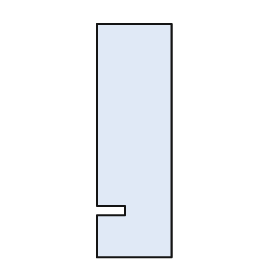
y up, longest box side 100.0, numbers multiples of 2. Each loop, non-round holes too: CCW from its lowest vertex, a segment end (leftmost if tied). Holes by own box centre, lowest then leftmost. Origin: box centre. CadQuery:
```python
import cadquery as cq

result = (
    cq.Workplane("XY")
    .moveTo(-16.0, -50.0)
    .lineTo(16.0, -50.0)
    .lineTo(16.0, 50.0)
    .lineTo(-16.0, 50.0)
    .lineTo(-16.0, -28.0)
    .lineTo(-4.0, -28.0)
    .lineTo(-4.0, -32.0)
    .lineTo(-16.0, -32.0)
    .close()
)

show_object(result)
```